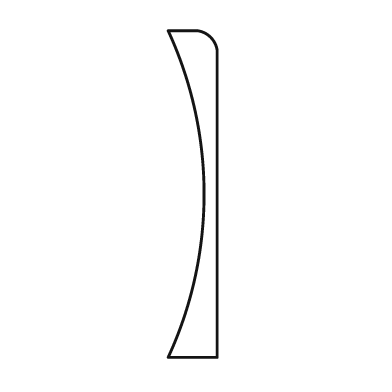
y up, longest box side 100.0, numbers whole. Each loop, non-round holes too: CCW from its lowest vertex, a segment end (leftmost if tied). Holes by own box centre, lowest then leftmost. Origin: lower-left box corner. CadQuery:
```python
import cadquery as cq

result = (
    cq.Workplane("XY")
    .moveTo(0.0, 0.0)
    .lineTo(15.0, 0.0)
    .lineTo(15.0, 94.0)
    .threePointArc((13.0, 98.0), (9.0, 100.0))
    .lineTo(0.0, 100.0)
    .threePointArc((11.0, 50.0), (0.0, 0.0))
    .close()
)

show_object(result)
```